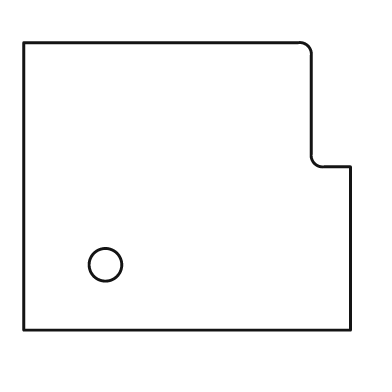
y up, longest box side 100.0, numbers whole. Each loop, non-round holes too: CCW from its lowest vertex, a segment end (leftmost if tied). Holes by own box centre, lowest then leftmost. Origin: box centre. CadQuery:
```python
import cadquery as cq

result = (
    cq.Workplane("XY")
    .moveTo(-50.0, -44.0)
    .lineTo(50.0, -44.0)
    .lineTo(50.0, 6.0)
    .lineTo(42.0, 6.0)
    .threePointArc((39.0, 7.0), (38.0, 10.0))
    .lineTo(38.0, 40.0)
    .threePointArc((37.0, 43.0), (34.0, 44.0))
    .lineTo(-50.0, 44.0)
    .close()
    .moveTo(-25.0, -24.0)
    .circle(5.0)
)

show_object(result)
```